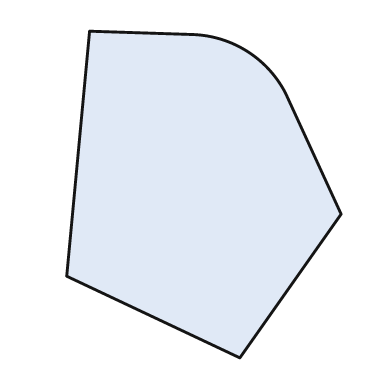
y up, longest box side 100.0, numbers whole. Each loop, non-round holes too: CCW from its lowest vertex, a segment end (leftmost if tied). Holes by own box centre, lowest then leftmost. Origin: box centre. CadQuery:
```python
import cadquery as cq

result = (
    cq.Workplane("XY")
    .moveTo(11.0, -50.0)
    .lineTo(42.0, -6.0)
    .lineTo(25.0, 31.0)
    .threePointArc((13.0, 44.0), (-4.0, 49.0))
    .lineTo(-35.0, 50.0)
    .lineTo(-42.0, -25.0)
    .close()
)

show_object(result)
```